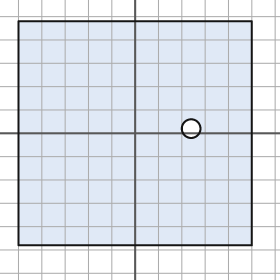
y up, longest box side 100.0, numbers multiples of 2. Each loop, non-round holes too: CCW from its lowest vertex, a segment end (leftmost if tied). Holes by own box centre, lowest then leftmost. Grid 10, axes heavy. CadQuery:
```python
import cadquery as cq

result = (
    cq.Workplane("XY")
    .moveTo(-50.0, -48.0)
    .lineTo(50.0, -48.0)
    .lineTo(50.0, 48.0)
    .lineTo(-50.0, 48.0)
    .close()
    .moveTo(24.0, 2.0)
    .circle(4.0)
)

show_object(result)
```